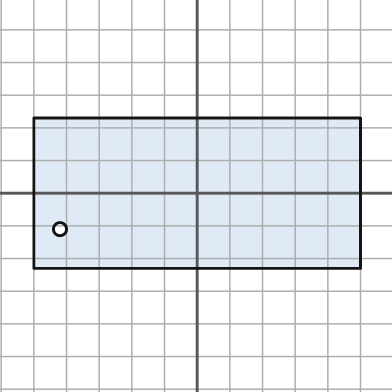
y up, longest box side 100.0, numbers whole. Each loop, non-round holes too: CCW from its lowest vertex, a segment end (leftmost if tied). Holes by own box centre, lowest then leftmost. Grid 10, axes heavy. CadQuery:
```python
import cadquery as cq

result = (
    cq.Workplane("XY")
    .moveTo(-50.0, -23.0)
    .lineTo(50.0, -23.0)
    .lineTo(50.0, 23.0)
    .lineTo(-50.0, 23.0)
    .close()
    .moveTo(-42.0, -11.0)
    .circle(2.0)
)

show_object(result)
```